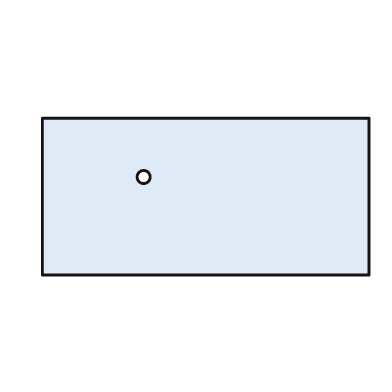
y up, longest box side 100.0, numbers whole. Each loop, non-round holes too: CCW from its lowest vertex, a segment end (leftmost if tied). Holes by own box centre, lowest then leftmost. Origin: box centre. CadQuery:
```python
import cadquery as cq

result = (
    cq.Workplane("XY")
    .moveTo(-50.0, -24.0)
    .lineTo(50.0, -24.0)
    .lineTo(50.0, 24.0)
    .lineTo(-50.0, 24.0)
    .close()
    .moveTo(-19.0, 6.0)
    .circle(2.0)
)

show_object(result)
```